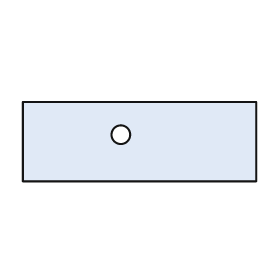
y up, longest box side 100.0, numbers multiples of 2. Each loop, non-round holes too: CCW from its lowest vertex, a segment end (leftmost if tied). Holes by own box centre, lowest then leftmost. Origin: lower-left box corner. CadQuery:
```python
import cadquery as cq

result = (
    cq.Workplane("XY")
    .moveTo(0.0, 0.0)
    .lineTo(100.0, 0.0)
    .lineTo(100.0, 34.0)
    .lineTo(0.0, 34.0)
    .close()
    .moveTo(42.0, 20.0)
    .circle(4.0)
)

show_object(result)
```